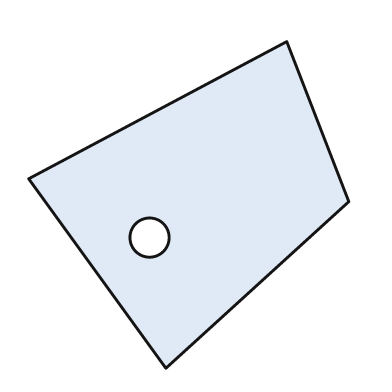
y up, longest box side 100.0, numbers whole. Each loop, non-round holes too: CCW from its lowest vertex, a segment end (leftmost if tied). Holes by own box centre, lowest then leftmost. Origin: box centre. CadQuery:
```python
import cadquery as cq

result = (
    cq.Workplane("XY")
    .moveTo(-7.0, -50.0)
    .lineTo(49.0, 1.0)
    .lineTo(30.0, 50.0)
    .lineTo(-49.0, 8.0)
    .close()
    .moveTo(-12.0, -10.0)
    .circle(6.0)
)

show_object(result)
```